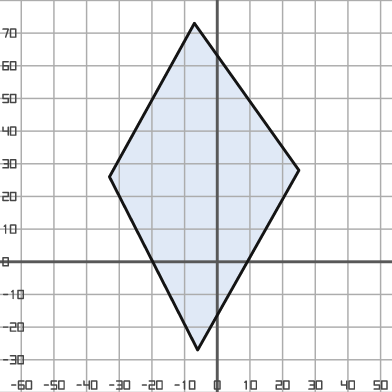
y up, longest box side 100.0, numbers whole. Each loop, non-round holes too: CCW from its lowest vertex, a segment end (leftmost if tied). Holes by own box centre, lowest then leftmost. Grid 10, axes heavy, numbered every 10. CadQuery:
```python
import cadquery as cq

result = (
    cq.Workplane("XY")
    .moveTo(-6.0, -27.0)
    .lineTo(25.0, 28.0)
    .lineTo(-7.0, 73.0)
    .lineTo(-33.0, 26.0)
    .close()
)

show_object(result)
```